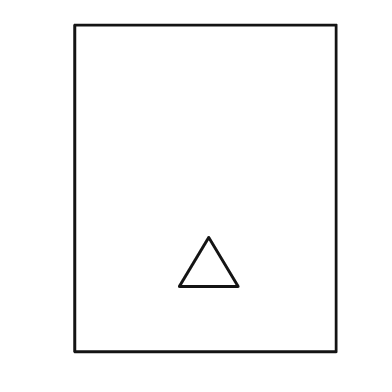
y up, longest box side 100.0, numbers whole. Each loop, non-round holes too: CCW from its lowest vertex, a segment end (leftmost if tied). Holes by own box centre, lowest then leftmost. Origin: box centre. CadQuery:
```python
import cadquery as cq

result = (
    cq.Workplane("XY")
    .moveTo(-40.0, -50.0)
    .lineTo(40.0, -50.0)
    .lineTo(40.0, 50.0)
    .lineTo(-40.0, 50.0)
    .close()
    .moveTo(-8.0, -30.0)
    .lineTo(10.0, -30.0)
    .lineTo(1.0, -15.0)
    .close()
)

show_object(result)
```